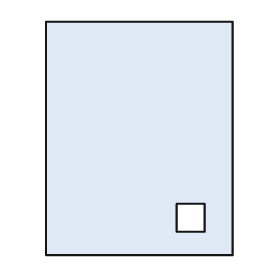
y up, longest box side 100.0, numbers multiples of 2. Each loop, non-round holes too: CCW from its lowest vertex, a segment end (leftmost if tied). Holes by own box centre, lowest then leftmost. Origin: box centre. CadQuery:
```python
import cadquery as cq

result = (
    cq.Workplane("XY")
    .moveTo(-40.0, -50.0)
    .lineTo(40.0, -50.0)
    .lineTo(40.0, 50.0)
    .lineTo(-40.0, 50.0)
    .close()
    .moveTo(16.0, -40.0)
    .lineTo(28.0, -40.0)
    .lineTo(28.0, -28.0)
    .lineTo(16.0, -28.0)
    .close()
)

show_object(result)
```